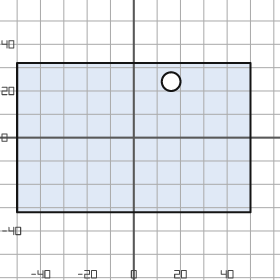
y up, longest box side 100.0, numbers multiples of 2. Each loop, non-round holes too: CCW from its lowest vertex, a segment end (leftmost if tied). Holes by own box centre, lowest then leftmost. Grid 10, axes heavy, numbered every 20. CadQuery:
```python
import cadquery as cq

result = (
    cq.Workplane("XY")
    .moveTo(-50.0, -32.0)
    .lineTo(50.0, -32.0)
    .lineTo(50.0, 32.0)
    .lineTo(-50.0, 32.0)
    .close()
    .moveTo(16.0, 24.0)
    .circle(4.0)
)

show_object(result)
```